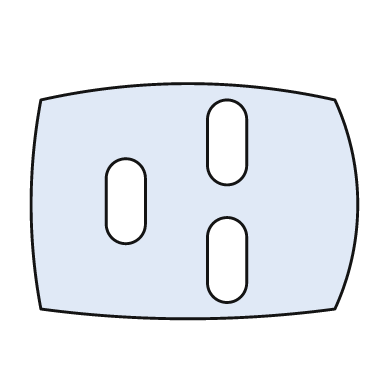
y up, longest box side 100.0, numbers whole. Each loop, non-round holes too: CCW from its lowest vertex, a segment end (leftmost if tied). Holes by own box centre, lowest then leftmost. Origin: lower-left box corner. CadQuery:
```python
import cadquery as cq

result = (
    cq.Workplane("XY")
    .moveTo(3.0, 3.0)
    .threePointArc((48.0, 0.0), (93.0, 3.0))
    .threePointArc((100.0, 35.0), (93.0, 67.0))
    .threePointArc((48.0, 72.0), (3.0, 67.0))
    .threePointArc((0.0, 35.0), (3.0, 3.0))
    .close()
    .moveTo(54.0, 11.0)
    .threePointArc((60.0, 5.0), (66.0, 11.0))
    .lineTo(66.0, 25.0)
    .threePointArc((60.0, 31.0), (54.0, 25.0))
    .close()
    .moveTo(23.0, 29.0)
    .threePointArc((29.0, 23.0), (35.0, 29.0))
    .lineTo(35.0, 43.0)
    .threePointArc((29.0, 49.0), (23.0, 43.0))
    .close()
    .moveTo(54.0, 47.0)
    .threePointArc((60.0, 41.0), (66.0, 47.0))
    .lineTo(66.0, 61.0)
    .threePointArc((60.0, 67.0), (54.0, 61.0))
    .close()
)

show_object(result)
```